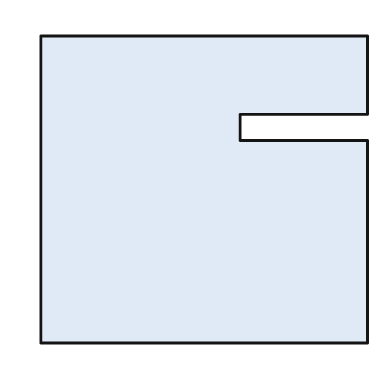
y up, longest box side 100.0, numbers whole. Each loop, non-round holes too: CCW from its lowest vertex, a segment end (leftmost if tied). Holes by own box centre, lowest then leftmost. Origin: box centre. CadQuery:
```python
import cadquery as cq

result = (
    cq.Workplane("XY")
    .moveTo(-50.0, -47.0)
    .lineTo(50.0, -47.0)
    .lineTo(50.0, 15.0)
    .lineTo(11.0, 15.0)
    .lineTo(11.0, 23.0)
    .lineTo(50.0, 23.0)
    .lineTo(50.0, 47.0)
    .lineTo(-50.0, 47.0)
    .close()
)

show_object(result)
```